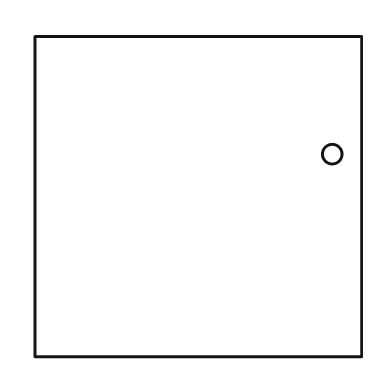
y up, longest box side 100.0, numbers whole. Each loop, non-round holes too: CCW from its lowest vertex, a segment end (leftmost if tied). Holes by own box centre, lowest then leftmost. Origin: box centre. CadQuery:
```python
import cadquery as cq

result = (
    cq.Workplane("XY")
    .moveTo(-50.0, -49.0)
    .lineTo(50.0, -49.0)
    .lineTo(50.0, 49.0)
    .lineTo(-50.0, 49.0)
    .close()
    .moveTo(41.0, 13.0)
    .circle(3.0)
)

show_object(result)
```